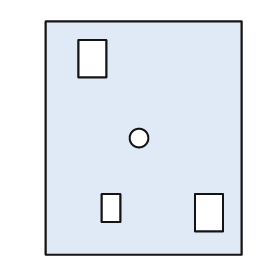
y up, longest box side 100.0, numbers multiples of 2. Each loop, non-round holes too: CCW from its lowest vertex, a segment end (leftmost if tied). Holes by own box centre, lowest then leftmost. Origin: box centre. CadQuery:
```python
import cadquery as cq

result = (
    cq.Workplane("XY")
    .moveTo(-42.0, -50.0)
    .lineTo(42.0, -50.0)
    .lineTo(42.0, 50.0)
    .lineTo(-42.0, 50.0)
    .close()
    .moveTo(22.0, -40.0)
    .lineTo(34.0, -40.0)
    .lineTo(34.0, -24.0)
    .lineTo(22.0, -24.0)
    .close()
    .moveTo(-18.0, -36.0)
    .lineTo(-10.0, -36.0)
    .lineTo(-10.0, -24.0)
    .lineTo(-18.0, -24.0)
    .close()
    .moveTo(-2.0, 0.0)
    .circle(4.0)
    .moveTo(-28.0, 26.0)
    .lineTo(-16.0, 26.0)
    .lineTo(-16.0, 42.0)
    .lineTo(-28.0, 42.0)
    .close()
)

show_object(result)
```